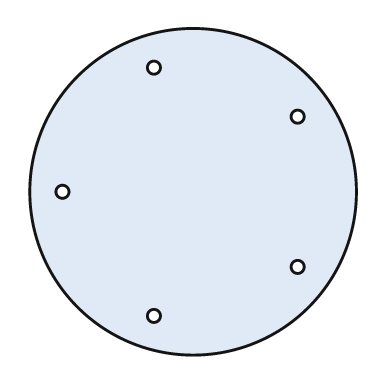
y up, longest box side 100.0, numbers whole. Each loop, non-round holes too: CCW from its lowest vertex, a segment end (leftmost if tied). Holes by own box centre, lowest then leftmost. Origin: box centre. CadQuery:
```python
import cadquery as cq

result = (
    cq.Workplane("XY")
    .moveTo(0.0, 0.0)
    .circle(50.0)
    .moveTo(-12.0, -38.0)
    .circle(2.0)
    .moveTo(32.0, -23.0)
    .circle(2.0)
    .moveTo(-40.0, 0.0)
    .circle(2.0)
    .moveTo(32.0, 23.0)
    .circle(2.0)
    .moveTo(-12.0, 38.0)
    .circle(2.0)
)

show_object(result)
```